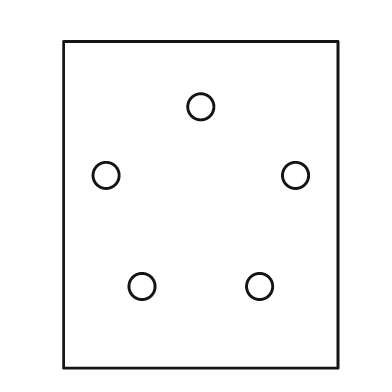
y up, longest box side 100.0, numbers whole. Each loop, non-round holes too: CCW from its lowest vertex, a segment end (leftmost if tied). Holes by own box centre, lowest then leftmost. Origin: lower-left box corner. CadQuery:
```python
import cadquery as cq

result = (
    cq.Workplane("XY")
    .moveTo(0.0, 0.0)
    .lineTo(84.0, 0.0)
    .lineTo(84.0, 100.0)
    .lineTo(0.0, 100.0)
    .close()
    .moveTo(24.0, 25.0)
    .circle(4.0)
    .moveTo(60.0, 25.0)
    .circle(4.0)
    .moveTo(13.0, 59.0)
    .circle(4.0)
    .moveTo(71.0, 59.0)
    .circle(4.0)
    .moveTo(42.0, 80.0)
    .circle(4.0)
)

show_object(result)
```